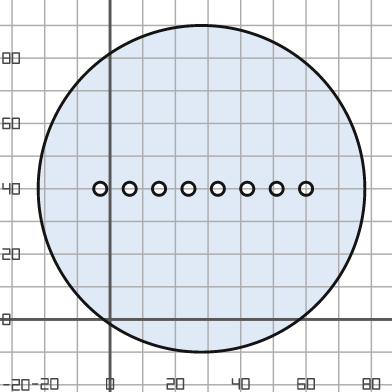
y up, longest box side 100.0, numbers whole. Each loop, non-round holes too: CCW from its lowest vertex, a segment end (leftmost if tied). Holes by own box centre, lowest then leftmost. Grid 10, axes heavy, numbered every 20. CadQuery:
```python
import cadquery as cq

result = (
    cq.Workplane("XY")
    .moveTo(28.0, 40.0)
    .circle(50.0)
    .moveTo(-3.0, 40.0)
    .circle(2.0)
    .moveTo(6.0, 40.0)
    .circle(2.0)
    .moveTo(15.0, 40.0)
    .circle(2.0)
    .moveTo(24.0, 40.0)
    .circle(2.0)
    .moveTo(33.0, 40.0)
    .circle(2.0)
    .moveTo(42.0, 40.0)
    .circle(2.0)
    .moveTo(51.0, 40.0)
    .circle(2.0)
    .moveTo(60.0, 40.0)
    .circle(2.0)
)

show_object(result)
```